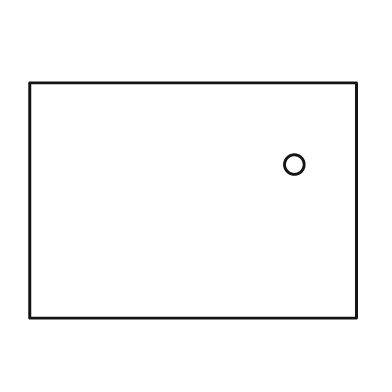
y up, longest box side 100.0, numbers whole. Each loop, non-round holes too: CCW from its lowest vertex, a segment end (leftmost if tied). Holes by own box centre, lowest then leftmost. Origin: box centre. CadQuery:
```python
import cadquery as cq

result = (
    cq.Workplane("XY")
    .moveTo(-50.0, -36.0)
    .lineTo(50.0, -36.0)
    .lineTo(50.0, 36.0)
    .lineTo(-50.0, 36.0)
    .close()
    .moveTo(31.0, 11.0)
    .circle(3.0)
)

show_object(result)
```